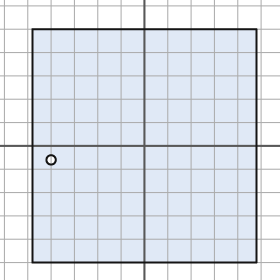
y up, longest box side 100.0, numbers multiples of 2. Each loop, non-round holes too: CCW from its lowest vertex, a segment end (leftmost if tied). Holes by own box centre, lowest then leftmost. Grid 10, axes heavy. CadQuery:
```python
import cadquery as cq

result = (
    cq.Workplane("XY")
    .moveTo(-48.0, -50.0)
    .lineTo(48.0, -50.0)
    .lineTo(48.0, 50.0)
    .lineTo(-48.0, 50.0)
    .close()
    .moveTo(-40.0, -6.0)
    .circle(2.0)
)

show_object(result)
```